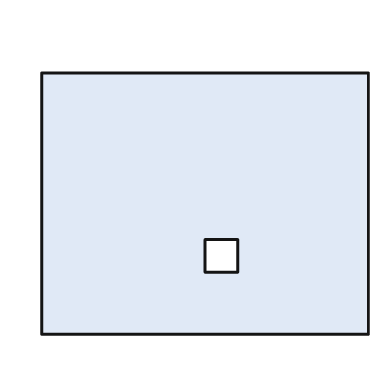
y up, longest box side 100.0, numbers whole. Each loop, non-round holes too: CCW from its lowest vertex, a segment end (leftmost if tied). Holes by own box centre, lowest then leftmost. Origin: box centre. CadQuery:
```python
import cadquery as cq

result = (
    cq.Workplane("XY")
    .moveTo(-50.0, -40.0)
    .lineTo(50.0, -40.0)
    .lineTo(50.0, 40.0)
    .lineTo(-50.0, 40.0)
    .close()
    .moveTo(0.0, -21.0)
    .lineTo(10.0, -21.0)
    .lineTo(10.0, -11.0)
    .lineTo(0.0, -11.0)
    .close()
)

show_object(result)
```